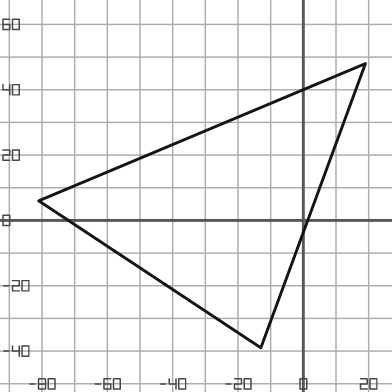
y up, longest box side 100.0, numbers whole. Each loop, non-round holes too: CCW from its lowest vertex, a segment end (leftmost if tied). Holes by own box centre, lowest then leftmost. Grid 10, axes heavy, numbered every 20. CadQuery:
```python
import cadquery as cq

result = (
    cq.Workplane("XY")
    .moveTo(-13.0, -39.0)
    .lineTo(19.0, 48.0)
    .lineTo(-81.0, 6.0)
    .close()
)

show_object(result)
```